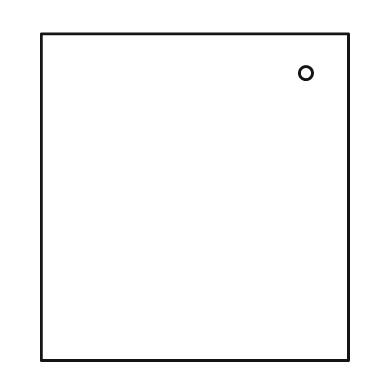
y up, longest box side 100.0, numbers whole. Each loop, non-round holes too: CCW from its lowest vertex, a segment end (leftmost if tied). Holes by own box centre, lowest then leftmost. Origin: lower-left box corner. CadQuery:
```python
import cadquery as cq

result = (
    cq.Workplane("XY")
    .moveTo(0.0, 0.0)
    .lineTo(94.0, 0.0)
    .lineTo(94.0, 100.0)
    .lineTo(0.0, 100.0)
    .close()
    .moveTo(81.0, 88.0)
    .circle(2.0)
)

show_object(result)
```